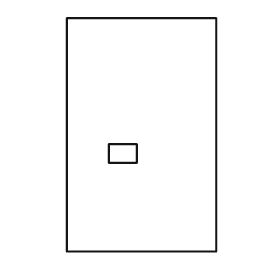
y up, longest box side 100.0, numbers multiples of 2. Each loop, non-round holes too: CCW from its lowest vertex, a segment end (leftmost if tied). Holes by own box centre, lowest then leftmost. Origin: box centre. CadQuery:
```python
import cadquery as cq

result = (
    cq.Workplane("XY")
    .moveTo(-32.0, -50.0)
    .lineTo(32.0, -50.0)
    .lineTo(32.0, 50.0)
    .lineTo(-32.0, 50.0)
    .close()
    .moveTo(-14.0, -12.0)
    .lineTo(-2.0, -12.0)
    .lineTo(-2.0, -4.0)
    .lineTo(-14.0, -4.0)
    .close()
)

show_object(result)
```